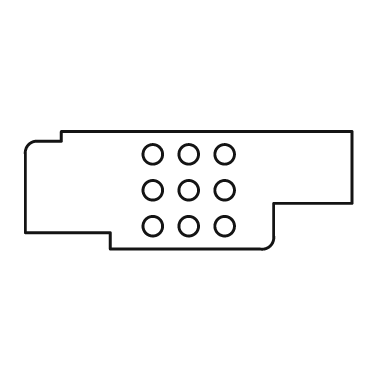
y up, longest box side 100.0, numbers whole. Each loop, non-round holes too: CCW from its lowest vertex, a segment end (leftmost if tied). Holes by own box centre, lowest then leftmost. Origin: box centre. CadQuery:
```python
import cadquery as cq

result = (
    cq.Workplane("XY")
    .moveTo(-24.0, -18.0)
    .lineTo(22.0, -18.0)
    .threePointArc((25.0, -17.0), (26.0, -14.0))
    .lineTo(26.0, -4.0)
    .lineTo(50.0, -4.0)
    .lineTo(50.0, 18.0)
    .lineTo(-39.0, 18.0)
    .lineTo(-39.0, 15.0)
    .lineTo(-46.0, 15.0)
    .threePointArc((-49.0, 14.0), (-50.0, 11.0))
    .lineTo(-50.0, -13.0)
    .lineTo(-24.0, -13.0)
    .close()
    .moveTo(-11.0, -11.0)
    .circle(3.0)
    .moveTo(0.0, -11.0)
    .circle(3.0)
    .moveTo(11.0, -11.0)
    .circle(3.0)
    .moveTo(-11.0, 0.0)
    .circle(3.0)
    .moveTo(0.0, 0.0)
    .circle(3.0)
    .moveTo(11.0, 0.0)
    .circle(3.0)
    .moveTo(-11.0, 11.0)
    .circle(3.0)
    .moveTo(0.0, 11.0)
    .circle(3.0)
    .moveTo(11.0, 11.0)
    .circle(3.0)
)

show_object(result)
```